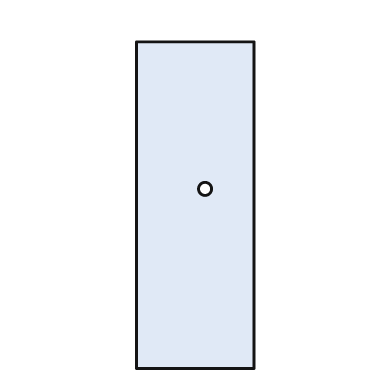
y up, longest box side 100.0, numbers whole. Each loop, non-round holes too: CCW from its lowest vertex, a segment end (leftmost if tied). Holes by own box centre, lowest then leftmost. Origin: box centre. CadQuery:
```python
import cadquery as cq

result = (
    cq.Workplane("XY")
    .moveTo(-18.0, -50.0)
    .lineTo(18.0, -50.0)
    .lineTo(18.0, 50.0)
    .lineTo(-18.0, 50.0)
    .close()
    .moveTo(3.0, 5.0)
    .circle(2.0)
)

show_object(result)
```